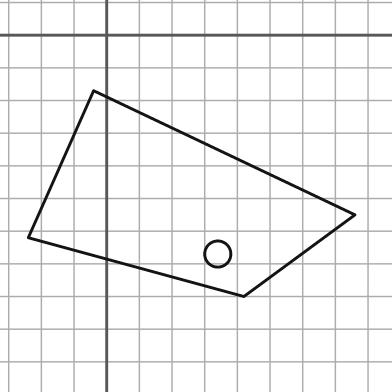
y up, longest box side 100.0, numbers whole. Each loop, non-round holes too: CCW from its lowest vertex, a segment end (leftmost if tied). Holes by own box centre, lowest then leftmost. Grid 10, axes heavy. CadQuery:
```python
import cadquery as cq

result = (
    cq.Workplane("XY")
    .moveTo(42.0, -80.0)
    .lineTo(76.0, -55.0)
    .lineTo(-4.0, -17.0)
    .lineTo(-24.0, -62.0)
    .close()
    .moveTo(34.0, -67.0)
    .circle(4.0)
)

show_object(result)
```